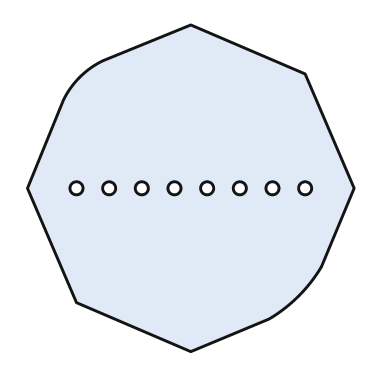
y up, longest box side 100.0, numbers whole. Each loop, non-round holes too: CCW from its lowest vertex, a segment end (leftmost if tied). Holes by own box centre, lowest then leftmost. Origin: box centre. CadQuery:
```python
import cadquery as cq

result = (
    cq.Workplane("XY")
    .moveTo(0.0, -50.0)
    .lineTo(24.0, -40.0)
    .threePointArc((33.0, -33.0), (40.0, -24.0))
    .lineTo(50.0, 0.0)
    .lineTo(35.0, 35.0)
    .lineTo(0.0, 50.0)
    .lineTo(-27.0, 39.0)
    .threePointArc((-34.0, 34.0), (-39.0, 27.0))
    .lineTo(-50.0, 0.0)
    .lineTo(-35.0, -35.0)
    .close()
    .moveTo(-35.0, 0.0)
    .circle(2.0)
    .moveTo(-25.0, 0.0)
    .circle(2.0)
    .moveTo(-15.0, 0.0)
    .circle(2.0)
    .moveTo(-5.0, 0.0)
    .circle(2.0)
    .moveTo(5.0, 0.0)
    .circle(2.0)
    .moveTo(15.0, 0.0)
    .circle(2.0)
    .moveTo(25.0, 0.0)
    .circle(2.0)
    .moveTo(35.0, 0.0)
    .circle(2.0)
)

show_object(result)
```